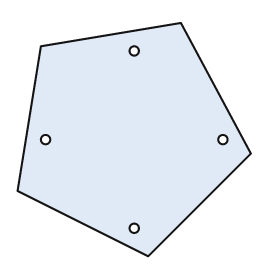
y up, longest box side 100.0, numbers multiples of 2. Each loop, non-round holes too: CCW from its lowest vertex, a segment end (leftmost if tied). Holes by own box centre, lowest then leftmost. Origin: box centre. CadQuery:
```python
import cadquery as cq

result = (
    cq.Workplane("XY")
    .moveTo(6.0, -50.0)
    .lineTo(50.0, -6.0)
    .lineTo(20.0, 50.0)
    .lineTo(-40.0, 40.0)
    .lineTo(-50.0, -22.0)
    .close()
    .moveTo(0.0, -38.0)
    .circle(2.0)
    .moveTo(-38.0, 0.0)
    .circle(2.0)
    .moveTo(38.0, 0.0)
    .circle(2.0)
    .moveTo(0.0, 38.0)
    .circle(2.0)
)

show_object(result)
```